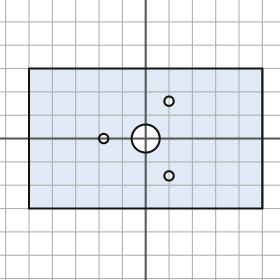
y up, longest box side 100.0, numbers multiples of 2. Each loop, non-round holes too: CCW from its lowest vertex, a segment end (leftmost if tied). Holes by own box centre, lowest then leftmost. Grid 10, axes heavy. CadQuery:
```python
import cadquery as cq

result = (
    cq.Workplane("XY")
    .moveTo(-50.0, -30.0)
    .lineTo(50.0, -30.0)
    .lineTo(50.0, 30.0)
    .lineTo(-50.0, 30.0)
    .close()
    .moveTo(10.0, -16.0)
    .circle(2.0)
    .moveTo(-18.0, 0.0)
    .circle(2.0)
    .moveTo(0.0, 0.0)
    .circle(6.0)
    .moveTo(10.0, 16.0)
    .circle(2.0)
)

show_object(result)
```